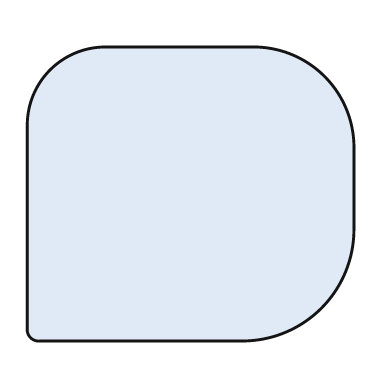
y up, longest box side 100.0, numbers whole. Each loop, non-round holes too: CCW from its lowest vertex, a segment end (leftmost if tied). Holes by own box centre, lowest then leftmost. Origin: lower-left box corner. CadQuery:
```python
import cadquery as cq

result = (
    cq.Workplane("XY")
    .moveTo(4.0, 0.0)
    .lineTo(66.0, 0.0)
    .threePointArc((90.0, 10.0), (100.0, 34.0))
    .lineTo(100.0, 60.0)
    .threePointArc((91.0, 81.0), (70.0, 90.0))
    .lineTo(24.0, 90.0)
    .threePointArc((7.0, 83.0), (0.0, 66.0))
    .lineTo(0.0, 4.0)
    .threePointArc((1.0, 1.0), (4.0, 0.0))
    .close()
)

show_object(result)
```